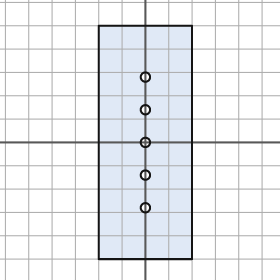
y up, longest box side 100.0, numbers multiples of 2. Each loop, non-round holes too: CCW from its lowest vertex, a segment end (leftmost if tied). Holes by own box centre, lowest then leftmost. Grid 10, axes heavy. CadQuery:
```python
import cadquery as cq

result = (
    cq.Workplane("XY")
    .moveTo(-20.0, -50.0)
    .lineTo(20.0, -50.0)
    .lineTo(20.0, 50.0)
    .lineTo(-20.0, 50.0)
    .close()
    .moveTo(0.0, -28.0)
    .circle(2.0)
    .moveTo(0.0, -14.0)
    .circle(2.0)
    .moveTo(0.0, 0.0)
    .circle(2.0)
    .moveTo(0.0, 14.0)
    .circle(2.0)
    .moveTo(0.0, 28.0)
    .circle(2.0)
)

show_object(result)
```